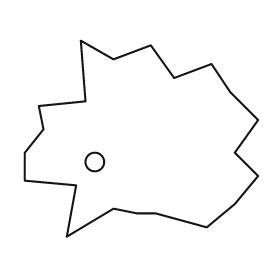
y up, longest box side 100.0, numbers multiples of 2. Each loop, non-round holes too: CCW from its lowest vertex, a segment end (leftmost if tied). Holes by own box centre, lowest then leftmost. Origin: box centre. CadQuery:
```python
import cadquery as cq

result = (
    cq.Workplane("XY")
    .moveTo(-32.0, -42.0)
    .lineTo(-12.0, -30.0)
    .lineTo(-2.0, -32.0)
    .lineTo(6.0, -32.0)
    .lineTo(28.0, -38.0)
    .lineTo(40.0, -28.0)
    .lineTo(50.0, -16.0)
    .lineTo(40.0, -6.0)
    .lineTo(50.0, 8.0)
    .lineTo(38.0, 20.0)
    .lineTo(30.0, 32.0)
    .lineTo(14.0, 26.0)
    .lineTo(4.0, 40.0)
    .lineTo(-12.0, 34.0)
    .lineTo(-26.0, 42.0)
    .lineTo(-24.0, 16.0)
    .lineTo(-44.0, 14.0)
    .lineTo(-42.0, 4.0)
    .lineTo(-50.0, -6.0)
    .lineTo(-50.0, -18.0)
    .lineTo(-28.0, -20.0)
    .close()
    .moveTo(-20.0, -10.0)
    .circle(4.0)
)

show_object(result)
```